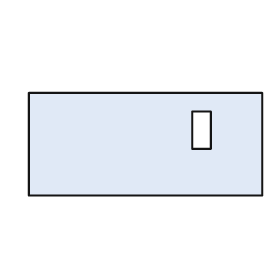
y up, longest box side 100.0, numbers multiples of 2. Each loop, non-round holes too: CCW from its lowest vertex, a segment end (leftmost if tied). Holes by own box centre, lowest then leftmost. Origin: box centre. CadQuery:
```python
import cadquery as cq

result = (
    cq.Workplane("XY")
    .moveTo(-50.0, -22.0)
    .lineTo(50.0, -22.0)
    .lineTo(50.0, 22.0)
    .lineTo(-50.0, 22.0)
    .close()
    .moveTo(20.0, -2.0)
    .lineTo(28.0, -2.0)
    .lineTo(28.0, 14.0)
    .lineTo(20.0, 14.0)
    .close()
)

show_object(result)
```